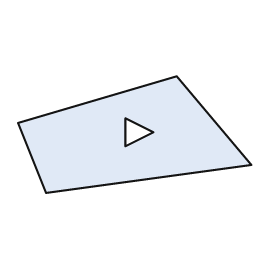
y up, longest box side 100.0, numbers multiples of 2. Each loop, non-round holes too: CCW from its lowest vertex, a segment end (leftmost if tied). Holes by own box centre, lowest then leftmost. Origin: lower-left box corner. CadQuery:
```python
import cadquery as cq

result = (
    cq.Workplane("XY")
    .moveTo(12.0, 0.0)
    .lineTo(100.0, 12.0)
    .lineTo(68.0, 50.0)
    .lineTo(0.0, 30.0)
    .close()
    .moveTo(46.0, 20.0)
    .lineTo(58.0, 26.0)
    .lineTo(46.0, 32.0)
    .close()
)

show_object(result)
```